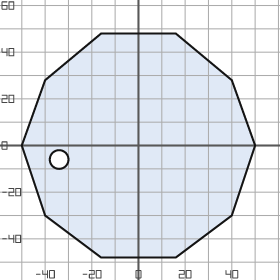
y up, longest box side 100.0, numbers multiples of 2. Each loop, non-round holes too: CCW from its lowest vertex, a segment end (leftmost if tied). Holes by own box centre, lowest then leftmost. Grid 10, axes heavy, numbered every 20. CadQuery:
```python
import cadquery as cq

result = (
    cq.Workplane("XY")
    .moveTo(-16.0, -48.0)
    .lineTo(16.0, -48.0)
    .lineTo(40.0, -30.0)
    .lineTo(50.0, 0.0)
    .lineTo(40.0, 28.0)
    .lineTo(16.0, 48.0)
    .lineTo(-16.0, 48.0)
    .lineTo(-40.0, 28.0)
    .lineTo(-50.0, 0.0)
    .lineTo(-40.0, -30.0)
    .close()
    .moveTo(-34.0, -6.0)
    .circle(4.0)
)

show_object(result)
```